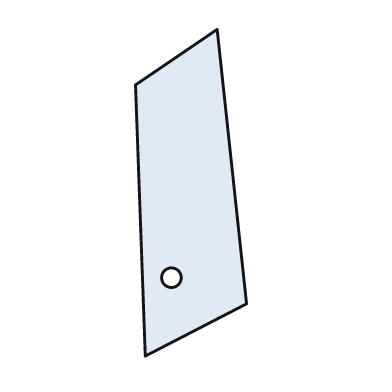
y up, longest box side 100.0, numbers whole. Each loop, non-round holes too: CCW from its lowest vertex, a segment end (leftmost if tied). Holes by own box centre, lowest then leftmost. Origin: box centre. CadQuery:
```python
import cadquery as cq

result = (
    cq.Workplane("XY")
    .moveTo(-14.0, -50.0)
    .lineTo(17.0, -34.0)
    .lineTo(8.0, 50.0)
    .lineTo(-17.0, 33.0)
    .close()
    .moveTo(-6.0, -26.0)
    .circle(3.0)
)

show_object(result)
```